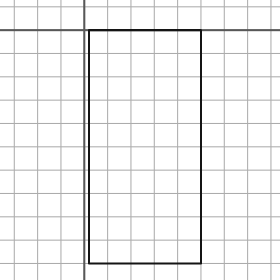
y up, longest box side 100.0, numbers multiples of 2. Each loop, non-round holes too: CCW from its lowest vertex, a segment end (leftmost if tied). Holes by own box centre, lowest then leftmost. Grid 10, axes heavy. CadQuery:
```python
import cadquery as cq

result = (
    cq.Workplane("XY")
    .moveTo(2.0, -100.0)
    .lineTo(50.0, -100.0)
    .lineTo(50.0, 0.0)
    .lineTo(2.0, 0.0)
    .close()
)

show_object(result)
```